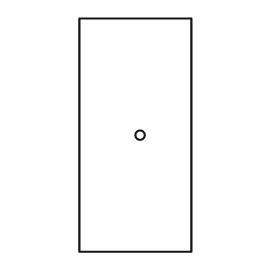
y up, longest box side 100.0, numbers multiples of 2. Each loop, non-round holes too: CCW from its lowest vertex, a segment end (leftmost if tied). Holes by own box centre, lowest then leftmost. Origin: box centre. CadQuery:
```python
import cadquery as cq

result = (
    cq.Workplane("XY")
    .moveTo(-24.0, -50.0)
    .lineTo(24.0, -50.0)
    .lineTo(24.0, 50.0)
    .lineTo(-24.0, 50.0)
    .close()
    .moveTo(2.0, 0.0)
    .circle(2.0)
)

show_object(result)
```